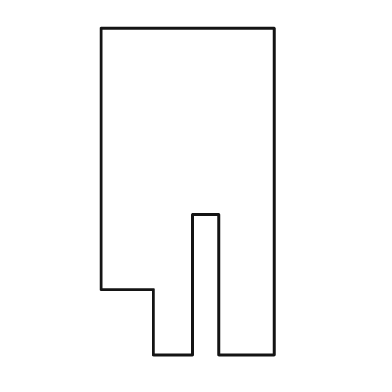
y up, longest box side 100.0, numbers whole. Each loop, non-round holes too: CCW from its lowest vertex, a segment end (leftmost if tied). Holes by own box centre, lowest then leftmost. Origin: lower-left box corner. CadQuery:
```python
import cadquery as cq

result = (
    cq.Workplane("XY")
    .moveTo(16.0, 0.0)
    .lineTo(28.0, 0.0)
    .lineTo(28.0, 43.0)
    .lineTo(36.0, 43.0)
    .lineTo(36.0, 0.0)
    .lineTo(53.0, 0.0)
    .lineTo(53.0, 100.0)
    .lineTo(0.0, 100.0)
    .lineTo(0.0, 20.0)
    .lineTo(16.0, 20.0)
    .close()
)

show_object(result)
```